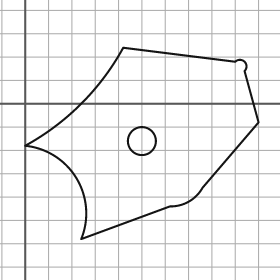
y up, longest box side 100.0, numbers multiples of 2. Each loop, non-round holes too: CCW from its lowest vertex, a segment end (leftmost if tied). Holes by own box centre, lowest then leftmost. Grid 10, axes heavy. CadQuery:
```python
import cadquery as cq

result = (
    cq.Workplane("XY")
    .moveTo(24.0, -58.0)
    .lineTo(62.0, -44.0)
    .threePointArc((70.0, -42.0), (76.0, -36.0))
    .lineTo(100.0, -8.0)
    .lineTo(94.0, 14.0)
    .threePointArc((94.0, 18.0), (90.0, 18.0))
    .lineTo(42.0, 24.0)
    .threePointArc((24.0, 0.0), (0.0, -18.0))
    .threePointArc((22.0, -32.0), (24.0, -58.0))
    .close()
    .moveTo(50.0, -16.0)
    .circle(6.0)
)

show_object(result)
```